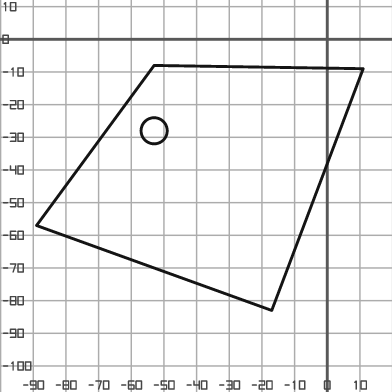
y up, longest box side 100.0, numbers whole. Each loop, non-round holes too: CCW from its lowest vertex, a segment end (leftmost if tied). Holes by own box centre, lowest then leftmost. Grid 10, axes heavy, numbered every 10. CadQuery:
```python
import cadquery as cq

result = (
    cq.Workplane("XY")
    .moveTo(-17.0, -83.0)
    .lineTo(11.0, -9.0)
    .lineTo(-53.0, -8.0)
    .lineTo(-89.0, -57.0)
    .close()
    .moveTo(-53.0, -28.0)
    .circle(4.0)
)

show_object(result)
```